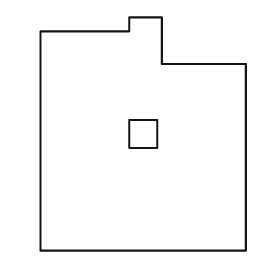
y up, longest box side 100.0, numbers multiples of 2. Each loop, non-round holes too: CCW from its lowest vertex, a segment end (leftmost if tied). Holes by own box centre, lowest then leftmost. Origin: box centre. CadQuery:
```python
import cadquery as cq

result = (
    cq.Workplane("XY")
    .moveTo(-44.0, -50.0)
    .lineTo(44.0, -50.0)
    .lineTo(44.0, 30.0)
    .lineTo(8.0, 30.0)
    .lineTo(8.0, 50.0)
    .lineTo(-6.0, 50.0)
    .lineTo(-6.0, 44.0)
    .lineTo(-44.0, 44.0)
    .close()
    .moveTo(-6.0, -6.0)
    .lineTo(6.0, -6.0)
    .lineTo(6.0, 6.0)
    .lineTo(-6.0, 6.0)
    .close()
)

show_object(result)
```